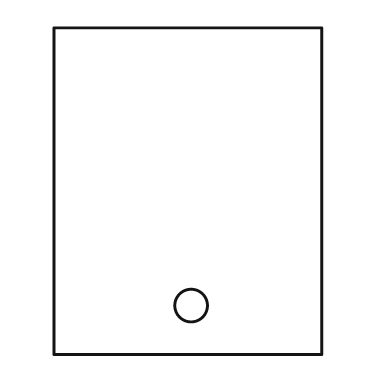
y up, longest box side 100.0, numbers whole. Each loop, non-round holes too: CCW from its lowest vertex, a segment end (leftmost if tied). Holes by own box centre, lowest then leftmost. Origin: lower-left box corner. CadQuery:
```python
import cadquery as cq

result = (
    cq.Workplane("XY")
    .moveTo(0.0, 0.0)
    .lineTo(82.0, 0.0)
    .lineTo(82.0, 100.0)
    .lineTo(0.0, 100.0)
    .close()
    .moveTo(42.0, 15.0)
    .circle(5.0)
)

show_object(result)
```